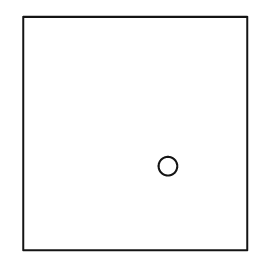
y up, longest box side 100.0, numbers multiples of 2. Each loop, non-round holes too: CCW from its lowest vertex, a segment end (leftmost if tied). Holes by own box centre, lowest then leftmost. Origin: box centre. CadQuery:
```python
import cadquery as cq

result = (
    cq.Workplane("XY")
    .moveTo(-48.0, -50.0)
    .lineTo(48.0, -50.0)
    .lineTo(48.0, 50.0)
    .lineTo(-48.0, 50.0)
    .close()
    .moveTo(14.0, -14.0)
    .circle(4.0)
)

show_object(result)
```